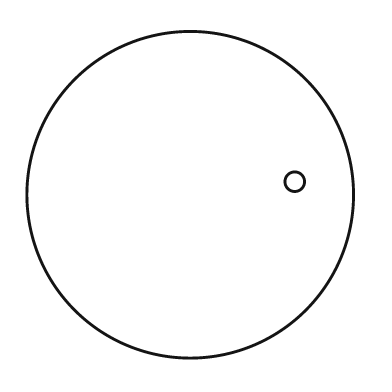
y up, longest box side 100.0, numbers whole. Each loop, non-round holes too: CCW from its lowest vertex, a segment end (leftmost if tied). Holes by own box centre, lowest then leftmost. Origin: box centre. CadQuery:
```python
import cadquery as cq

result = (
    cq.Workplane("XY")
    .moveTo(0.0, 0.0)
    .circle(50.0)
    .moveTo(32.0, 4.0)
    .circle(3.0)
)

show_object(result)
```